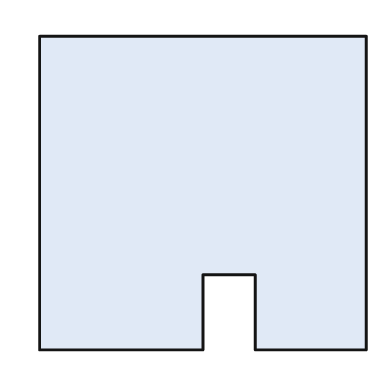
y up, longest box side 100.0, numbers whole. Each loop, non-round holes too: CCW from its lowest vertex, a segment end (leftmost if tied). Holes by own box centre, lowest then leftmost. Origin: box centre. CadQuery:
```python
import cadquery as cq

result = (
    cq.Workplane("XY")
    .moveTo(-50.0, -48.0)
    .lineTo(0.0, -48.0)
    .lineTo(0.0, -25.0)
    .lineTo(16.0, -25.0)
    .lineTo(16.0, -48.0)
    .lineTo(50.0, -48.0)
    .lineTo(50.0, 48.0)
    .lineTo(-50.0, 48.0)
    .close()
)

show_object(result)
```